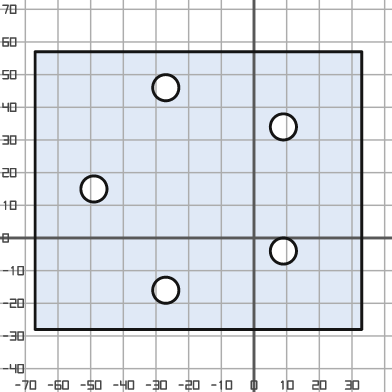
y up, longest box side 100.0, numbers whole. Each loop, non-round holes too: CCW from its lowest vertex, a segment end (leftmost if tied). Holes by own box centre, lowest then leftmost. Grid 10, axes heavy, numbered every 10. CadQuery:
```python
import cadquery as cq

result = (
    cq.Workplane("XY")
    .moveTo(-67.0, -28.0)
    .lineTo(33.0, -28.0)
    .lineTo(33.0, 57.0)
    .lineTo(-67.0, 57.0)
    .close()
    .moveTo(-27.0, -16.0)
    .circle(4.0)
    .moveTo(9.0, -4.0)
    .circle(4.0)
    .moveTo(-49.0, 15.0)
    .circle(4.0)
    .moveTo(9.0, 34.0)
    .circle(4.0)
    .moveTo(-27.0, 46.0)
    .circle(4.0)
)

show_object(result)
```